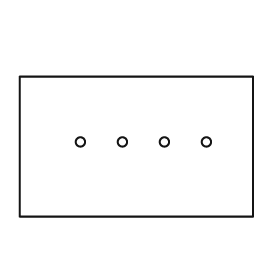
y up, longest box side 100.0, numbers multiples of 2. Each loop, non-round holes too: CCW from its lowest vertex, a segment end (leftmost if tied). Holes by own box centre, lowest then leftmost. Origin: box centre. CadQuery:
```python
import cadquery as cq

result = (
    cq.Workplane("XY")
    .moveTo(-50.0, -30.0)
    .lineTo(50.0, -30.0)
    .lineTo(50.0, 30.0)
    .lineTo(-50.0, 30.0)
    .close()
    .moveTo(-24.0, 2.0)
    .circle(2.0)
    .moveTo(-6.0, 2.0)
    .circle(2.0)
    .moveTo(12.0, 2.0)
    .circle(2.0)
    .moveTo(30.0, 2.0)
    .circle(2.0)
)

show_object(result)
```